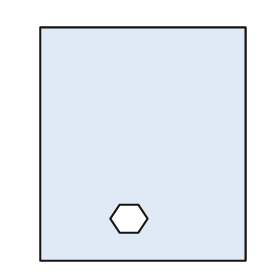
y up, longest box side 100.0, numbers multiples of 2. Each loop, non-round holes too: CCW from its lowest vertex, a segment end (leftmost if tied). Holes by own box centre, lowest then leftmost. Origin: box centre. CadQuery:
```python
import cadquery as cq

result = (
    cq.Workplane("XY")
    .moveTo(-44.0, -50.0)
    .lineTo(44.0, -50.0)
    .lineTo(44.0, 50.0)
    .lineTo(-44.0, 50.0)
    .close()
    .moveTo(-10.0, -38.0)
    .lineTo(-2.0, -38.0)
    .lineTo(2.0, -32.0)
    .lineTo(-2.0, -26.0)
    .lineTo(-10.0, -26.0)
    .lineTo(-14.0, -32.0)
    .close()
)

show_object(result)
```